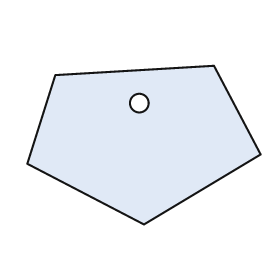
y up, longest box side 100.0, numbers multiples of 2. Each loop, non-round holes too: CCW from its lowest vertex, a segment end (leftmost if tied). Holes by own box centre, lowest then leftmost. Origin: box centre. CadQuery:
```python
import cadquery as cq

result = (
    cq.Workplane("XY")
    .moveTo(0.0, -34.0)
    .lineTo(50.0, -4.0)
    .lineTo(30.0, 34.0)
    .lineTo(-38.0, 30.0)
    .lineTo(-50.0, -8.0)
    .close()
    .moveTo(-2.0, 18.0)
    .circle(4.0)
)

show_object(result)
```